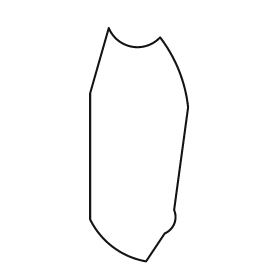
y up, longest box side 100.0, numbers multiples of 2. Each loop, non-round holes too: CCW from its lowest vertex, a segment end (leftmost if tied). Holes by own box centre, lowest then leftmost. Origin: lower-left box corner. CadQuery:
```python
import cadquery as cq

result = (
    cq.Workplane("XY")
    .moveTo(24.0, 0.0)
    .lineTo(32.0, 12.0)
    .threePointArc((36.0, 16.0), (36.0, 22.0))
    .lineTo(42.0, 66.0)
    .threePointArc((38.0, 82.0), (30.0, 96.0))
    .threePointArc((18.0, 92.0), (8.0, 100.0))
    .lineTo(0.0, 72.0)
    .lineTo(0.0, 18.0)
    .threePointArc((10.0, 6.0), (24.0, 0.0))
    .close()
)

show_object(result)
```